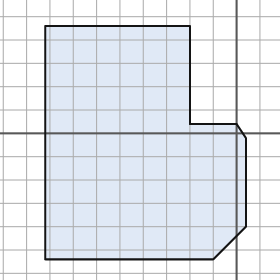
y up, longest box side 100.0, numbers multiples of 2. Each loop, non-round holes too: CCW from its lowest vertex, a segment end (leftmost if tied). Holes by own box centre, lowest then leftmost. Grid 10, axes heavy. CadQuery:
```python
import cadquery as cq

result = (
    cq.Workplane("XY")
    .moveTo(-82.0, -54.0)
    .lineTo(-10.0, -54.0)
    .lineTo(4.0, -40.0)
    .lineTo(4.0, -2.0)
    .lineTo(0.0, 4.0)
    .lineTo(-20.0, 4.0)
    .lineTo(-20.0, 46.0)
    .lineTo(-82.0, 46.0)
    .close()
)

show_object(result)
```